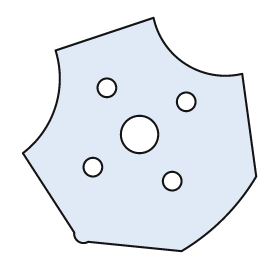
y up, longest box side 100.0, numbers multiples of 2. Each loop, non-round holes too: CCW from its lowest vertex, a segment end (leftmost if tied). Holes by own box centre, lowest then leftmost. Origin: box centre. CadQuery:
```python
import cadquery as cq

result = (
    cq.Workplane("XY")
    .moveTo(18.0, -50.0)
    .threePointArc((36.0, -36.0), (50.0, -18.0))
    .lineTo(44.0, 26.0)
    .threePointArc((20.0, 30.0), (6.0, 50.0))
    .lineTo(-36.0, 36.0)
    .threePointArc((-36.0, 12.0), (-50.0, -8.0))
    .lineTo(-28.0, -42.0)
    .threePointArc((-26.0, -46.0), (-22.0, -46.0))
    .close()
    .moveTo(14.0, -20.0)
    .circle(4.0)
    .moveTo(-20.0, -14.0)
    .circle(4.0)
    .moveTo(0.0, 0.0)
    .circle(8.0)
    .moveTo(20.0, 14.0)
    .circle(4.0)
    .moveTo(-14.0, 20.0)
    .circle(4.0)
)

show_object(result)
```